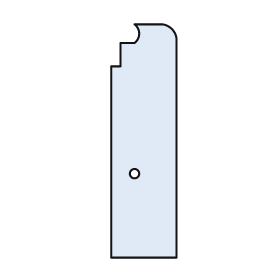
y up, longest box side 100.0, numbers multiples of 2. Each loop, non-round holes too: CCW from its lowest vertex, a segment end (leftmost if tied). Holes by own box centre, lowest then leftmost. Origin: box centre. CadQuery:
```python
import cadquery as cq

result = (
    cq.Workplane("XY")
    .moveTo(-14.0, -50.0)
    .lineTo(14.0, -50.0)
    .lineTo(14.0, 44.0)
    .threePointArc((12.0, 48.0), (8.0, 50.0))
    .lineTo(-4.0, 50.0)
    .threePointArc((-2.0, 46.0), (-4.0, 42.0))
    .lineTo(-10.0, 42.0)
    .lineTo(-10.0, 32.0)
    .lineTo(-14.0, 32.0)
    .close()
    .moveTo(-4.0, -14.0)
    .circle(2.0)
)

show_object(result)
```